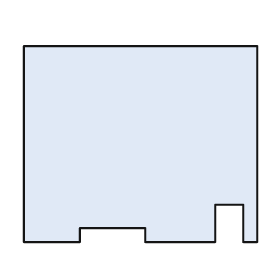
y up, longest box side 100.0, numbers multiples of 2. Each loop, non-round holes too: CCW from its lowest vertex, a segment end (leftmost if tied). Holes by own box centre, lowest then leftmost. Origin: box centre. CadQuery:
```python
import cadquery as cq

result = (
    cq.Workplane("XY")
    .moveTo(-50.0, -42.0)
    .lineTo(-26.0, -42.0)
    .lineTo(-26.0, -36.0)
    .lineTo(2.0, -36.0)
    .lineTo(2.0, -42.0)
    .lineTo(32.0, -42.0)
    .lineTo(32.0, -26.0)
    .lineTo(44.0, -26.0)
    .lineTo(44.0, -42.0)
    .lineTo(50.0, -42.0)
    .lineTo(50.0, 42.0)
    .lineTo(-50.0, 42.0)
    .close()
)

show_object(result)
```